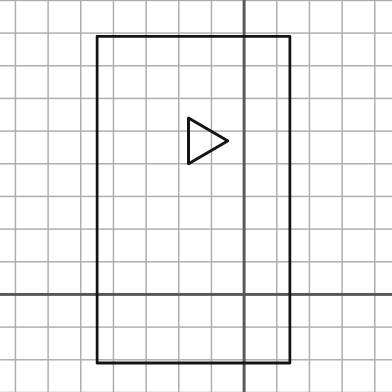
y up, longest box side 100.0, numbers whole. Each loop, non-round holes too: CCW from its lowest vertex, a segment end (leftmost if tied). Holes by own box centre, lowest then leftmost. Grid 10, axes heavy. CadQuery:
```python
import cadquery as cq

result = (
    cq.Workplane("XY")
    .moveTo(-45.0, -21.0)
    .lineTo(14.0, -21.0)
    .lineTo(14.0, 79.0)
    .lineTo(-45.0, 79.0)
    .close()
    .moveTo(-17.0, 40.0)
    .lineTo(-5.0, 47.0)
    .lineTo(-17.0, 54.0)
    .close()
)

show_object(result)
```